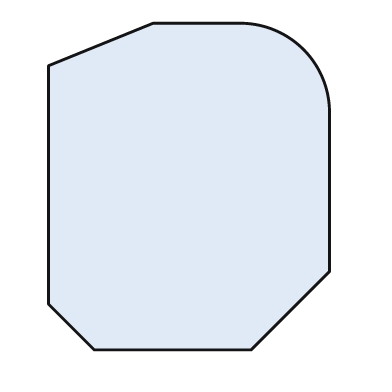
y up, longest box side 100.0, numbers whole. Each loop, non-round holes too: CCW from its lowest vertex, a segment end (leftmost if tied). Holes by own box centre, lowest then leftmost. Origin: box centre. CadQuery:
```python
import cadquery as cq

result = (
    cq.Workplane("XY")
    .moveTo(-29.0, -50.0)
    .lineTo(19.0, -50.0)
    .lineTo(43.0, -26.0)
    .lineTo(43.0, 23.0)
    .threePointArc((35.0, 42.0), (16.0, 50.0))
    .lineTo(-11.0, 50.0)
    .lineTo(-43.0, 37.0)
    .lineTo(-43.0, -36.0)
    .close()
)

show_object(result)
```